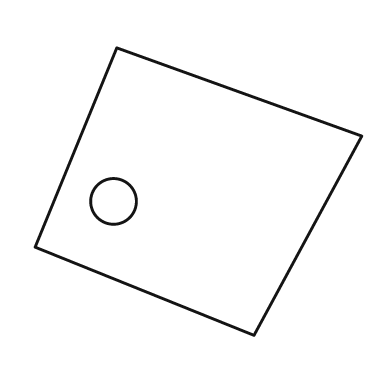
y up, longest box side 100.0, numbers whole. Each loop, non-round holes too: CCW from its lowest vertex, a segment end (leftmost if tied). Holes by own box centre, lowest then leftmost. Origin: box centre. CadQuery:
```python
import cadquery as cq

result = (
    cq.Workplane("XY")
    .moveTo(17.0, -44.0)
    .lineTo(50.0, 17.0)
    .lineTo(-25.0, 44.0)
    .lineTo(-50.0, -17.0)
    .close()
    .moveTo(-26.0, -3.0)
    .circle(7.0)
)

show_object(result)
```